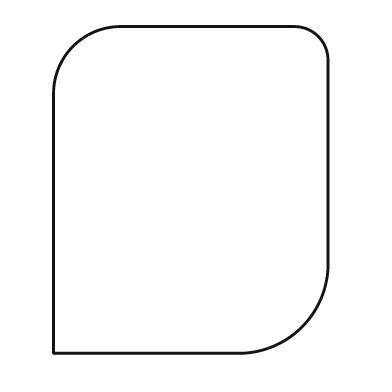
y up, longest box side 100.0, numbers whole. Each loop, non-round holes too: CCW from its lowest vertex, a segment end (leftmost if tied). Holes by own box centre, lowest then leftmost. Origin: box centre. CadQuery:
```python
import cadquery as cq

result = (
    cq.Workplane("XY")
    .moveTo(-42.0, -50.0)
    .lineTo(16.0, -50.0)
    .threePointArc((34.0, -42.0), (42.0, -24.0))
    .lineTo(42.0, 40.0)
    .threePointArc((39.0, 47.0), (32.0, 50.0))
    .lineTo(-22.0, 50.0)
    .threePointArc((-36.0, 44.0), (-42.0, 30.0))
    .close()
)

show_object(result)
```